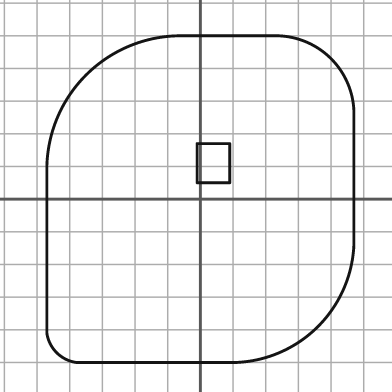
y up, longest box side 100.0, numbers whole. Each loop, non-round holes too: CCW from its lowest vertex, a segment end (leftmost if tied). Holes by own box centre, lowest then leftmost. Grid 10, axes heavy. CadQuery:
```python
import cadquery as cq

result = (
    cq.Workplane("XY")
    .moveTo(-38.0, -50.0)
    .lineTo(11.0, -50.0)
    .threePointArc((36.0, -39.0), (47.0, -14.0))
    .lineTo(47.0, 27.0)
    .threePointArc((40.0, 43.0), (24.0, 50.0))
    .lineTo(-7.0, 50.0)
    .threePointArc((-35.0, 38.0), (-47.0, 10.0))
    .lineTo(-47.0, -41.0)
    .threePointArc((-44.0, -47.0), (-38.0, -50.0))
    .close()
    .moveTo(-1.0, 5.0)
    .lineTo(9.0, 5.0)
    .lineTo(9.0, 17.0)
    .lineTo(-1.0, 17.0)
    .close()
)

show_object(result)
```